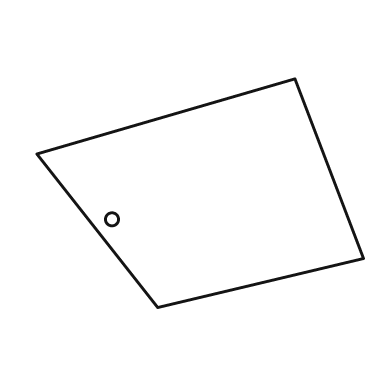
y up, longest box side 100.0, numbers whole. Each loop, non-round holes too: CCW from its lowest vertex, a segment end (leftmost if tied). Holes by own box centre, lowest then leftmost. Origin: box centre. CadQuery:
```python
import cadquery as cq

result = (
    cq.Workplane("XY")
    .moveTo(-13.0, -35.0)
    .lineTo(50.0, -20.0)
    .lineTo(29.0, 35.0)
    .lineTo(-50.0, 12.0)
    .close()
    .moveTo(-27.0, -8.0)
    .circle(2.0)
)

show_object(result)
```